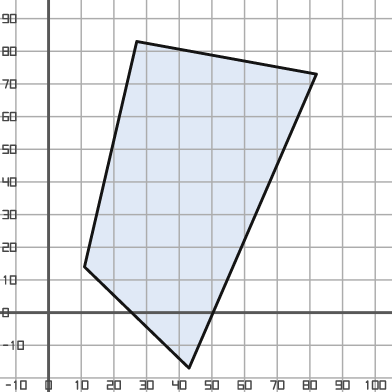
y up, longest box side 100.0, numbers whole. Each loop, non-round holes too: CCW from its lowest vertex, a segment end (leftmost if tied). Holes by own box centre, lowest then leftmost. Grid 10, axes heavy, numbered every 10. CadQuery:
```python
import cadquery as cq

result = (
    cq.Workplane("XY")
    .moveTo(43.0, -17.0)
    .lineTo(82.0, 73.0)
    .lineTo(27.0, 83.0)
    .lineTo(11.0, 14.0)
    .close()
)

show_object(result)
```